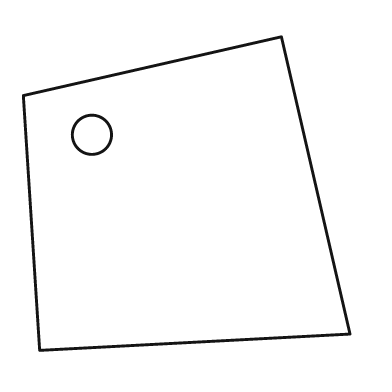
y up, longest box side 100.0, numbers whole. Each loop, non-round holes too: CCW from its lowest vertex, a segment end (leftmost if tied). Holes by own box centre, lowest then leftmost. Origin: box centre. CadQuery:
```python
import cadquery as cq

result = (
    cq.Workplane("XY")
    .moveTo(-45.0, -48.0)
    .lineTo(50.0, -43.0)
    .lineTo(29.0, 48.0)
    .lineTo(-50.0, 30.0)
    .close()
    .moveTo(-29.0, 18.0)
    .circle(6.0)
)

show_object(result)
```